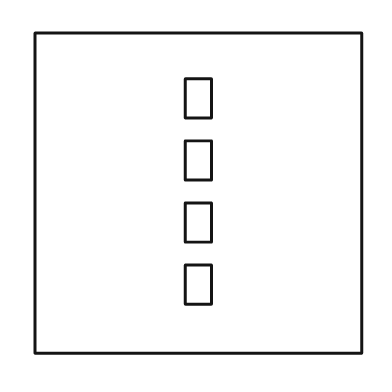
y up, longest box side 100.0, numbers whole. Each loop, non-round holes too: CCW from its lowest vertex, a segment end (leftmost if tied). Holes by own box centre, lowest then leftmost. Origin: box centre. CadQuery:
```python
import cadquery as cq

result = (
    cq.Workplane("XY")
    .moveTo(-50.0, -49.0)
    .lineTo(50.0, -49.0)
    .lineTo(50.0, 49.0)
    .lineTo(-50.0, 49.0)
    .close()
    .moveTo(-4.0, -34.0)
    .lineTo(4.0, -34.0)
    .lineTo(4.0, -22.0)
    .lineTo(-4.0, -22.0)
    .close()
    .moveTo(-4.0, -15.0)
    .lineTo(4.0, -15.0)
    .lineTo(4.0, -3.0)
    .lineTo(-4.0, -3.0)
    .close()
    .moveTo(-4.0, 4.0)
    .lineTo(4.0, 4.0)
    .lineTo(4.0, 16.0)
    .lineTo(-4.0, 16.0)
    .close()
    .moveTo(-4.0, 23.0)
    .lineTo(4.0, 23.0)
    .lineTo(4.0, 35.0)
    .lineTo(-4.0, 35.0)
    .close()
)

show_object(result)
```